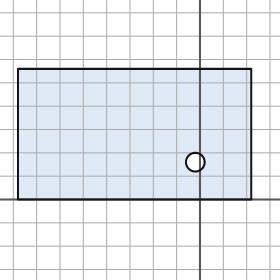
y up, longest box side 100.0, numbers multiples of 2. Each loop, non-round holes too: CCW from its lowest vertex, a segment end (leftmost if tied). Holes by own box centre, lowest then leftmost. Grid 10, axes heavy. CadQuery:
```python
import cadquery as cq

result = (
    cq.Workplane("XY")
    .moveTo(-78.0, 0.0)
    .lineTo(22.0, 0.0)
    .lineTo(22.0, 56.0)
    .lineTo(-78.0, 56.0)
    .close()
    .moveTo(-2.0, 16.0)
    .circle(4.0)
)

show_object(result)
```